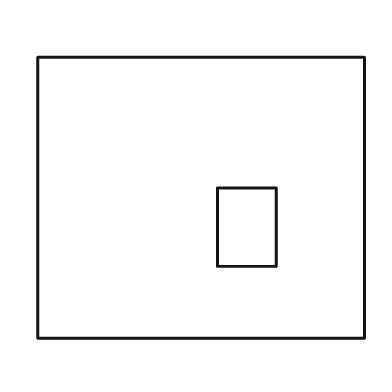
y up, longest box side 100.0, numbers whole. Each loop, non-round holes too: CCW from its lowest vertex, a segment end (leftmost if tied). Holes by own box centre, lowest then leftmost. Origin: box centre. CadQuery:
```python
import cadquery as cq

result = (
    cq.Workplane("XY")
    .moveTo(-50.0, -43.0)
    .lineTo(50.0, -43.0)
    .lineTo(50.0, 43.0)
    .lineTo(-50.0, 43.0)
    .close()
    .moveTo(5.0, -21.0)
    .lineTo(23.0, -21.0)
    .lineTo(23.0, 3.0)
    .lineTo(5.0, 3.0)
    .close()
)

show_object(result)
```